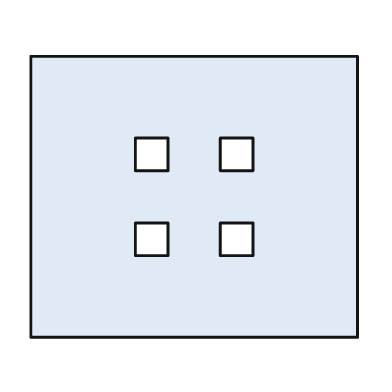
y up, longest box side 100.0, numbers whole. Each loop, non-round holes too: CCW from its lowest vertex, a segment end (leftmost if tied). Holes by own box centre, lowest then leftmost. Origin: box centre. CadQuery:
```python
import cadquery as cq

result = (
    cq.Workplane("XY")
    .moveTo(-50.0, -43.0)
    .lineTo(50.0, -43.0)
    .lineTo(50.0, 43.0)
    .lineTo(-50.0, 43.0)
    .close()
    .moveTo(-18.0, -18.0)
    .lineTo(-8.0, -18.0)
    .lineTo(-8.0, -8.0)
    .lineTo(-18.0, -8.0)
    .close()
    .moveTo(8.0, -18.0)
    .lineTo(18.0, -18.0)
    .lineTo(18.0, -8.0)
    .lineTo(8.0, -8.0)
    .close()
    .moveTo(-18.0, 8.0)
    .lineTo(-8.0, 8.0)
    .lineTo(-8.0, 18.0)
    .lineTo(-18.0, 18.0)
    .close()
    .moveTo(8.0, 8.0)
    .lineTo(18.0, 8.0)
    .lineTo(18.0, 18.0)
    .lineTo(8.0, 18.0)
    .close()
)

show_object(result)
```